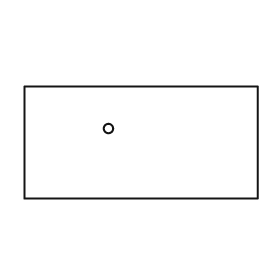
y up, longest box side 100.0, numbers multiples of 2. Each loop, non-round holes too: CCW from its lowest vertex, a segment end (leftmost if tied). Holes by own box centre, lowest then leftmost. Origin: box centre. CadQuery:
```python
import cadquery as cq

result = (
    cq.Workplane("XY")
    .moveTo(-50.0, -24.0)
    .lineTo(50.0, -24.0)
    .lineTo(50.0, 24.0)
    .lineTo(-50.0, 24.0)
    .close()
    .moveTo(-14.0, 6.0)
    .circle(2.0)
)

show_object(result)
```